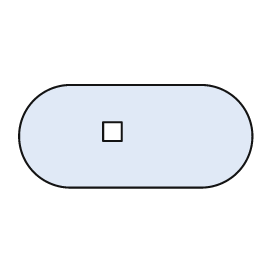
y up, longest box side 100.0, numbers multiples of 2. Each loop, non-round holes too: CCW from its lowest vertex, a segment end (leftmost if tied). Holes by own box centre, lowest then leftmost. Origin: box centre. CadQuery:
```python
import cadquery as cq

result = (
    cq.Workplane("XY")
    .moveTo(-28.0, -22.0)
    .lineTo(28.0, -22.0)
    .threePointArc((50.0, 0.0), (28.0, 22.0))
    .lineTo(-28.0, 22.0)
    .threePointArc((-50.0, 0.0), (-28.0, -22.0))
    .close()
    .moveTo(-14.0, -2.0)
    .lineTo(-6.0, -2.0)
    .lineTo(-6.0, 6.0)
    .lineTo(-14.0, 6.0)
    .close()
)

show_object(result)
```